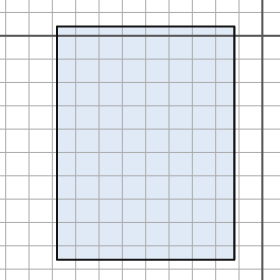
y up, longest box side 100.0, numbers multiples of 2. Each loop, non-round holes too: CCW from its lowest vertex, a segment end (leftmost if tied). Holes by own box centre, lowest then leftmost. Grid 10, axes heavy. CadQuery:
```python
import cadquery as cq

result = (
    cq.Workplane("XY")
    .moveTo(-88.0, -96.0)
    .lineTo(-12.0, -96.0)
    .lineTo(-12.0, 4.0)
    .lineTo(-88.0, 4.0)
    .close()
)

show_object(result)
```